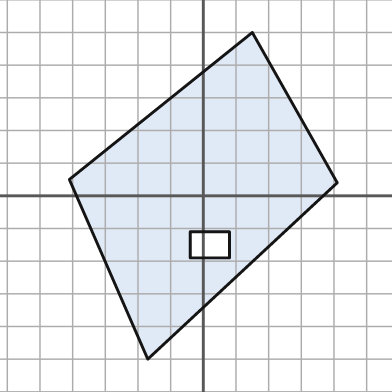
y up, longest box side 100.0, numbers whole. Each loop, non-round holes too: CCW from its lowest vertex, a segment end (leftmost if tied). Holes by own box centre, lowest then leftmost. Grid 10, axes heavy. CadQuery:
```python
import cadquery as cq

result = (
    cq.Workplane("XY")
    .moveTo(-17.0, -50.0)
    .lineTo(41.0, 4.0)
    .lineTo(15.0, 50.0)
    .lineTo(-41.0, 5.0)
    .close()
    .moveTo(-4.0, -19.0)
    .lineTo(8.0, -19.0)
    .lineTo(8.0, -11.0)
    .lineTo(-4.0, -11.0)
    .close()
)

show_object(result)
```